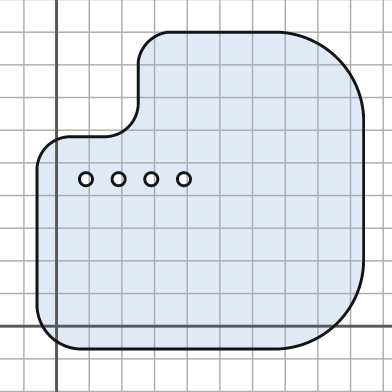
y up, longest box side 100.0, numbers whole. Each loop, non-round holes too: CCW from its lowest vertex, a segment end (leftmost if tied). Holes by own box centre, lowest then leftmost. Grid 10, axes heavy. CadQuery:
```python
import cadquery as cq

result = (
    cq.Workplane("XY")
    .moveTo(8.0, -7.0)
    .lineTo(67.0, -7.0)
    .threePointArc((86.0, 1.0), (94.0, 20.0))
    .lineTo(94.0, 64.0)
    .threePointArc((86.0, 82.0), (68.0, 90.0))
    .lineTo(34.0, 90.0)
    .threePointArc((28.0, 87.0), (25.0, 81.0))
    .lineTo(25.0, 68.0)
    .threePointArc((22.0, 61.0), (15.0, 58.0))
    .lineTo(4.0, 58.0)
    .threePointArc((-3.0, 55.0), (-6.0, 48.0))
    .lineTo(-6.0, 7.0)
    .threePointArc((-2.0, -3.0), (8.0, -7.0))
    .close()
    .moveTo(9.0, 45.0)
    .circle(2.0)
    .moveTo(19.0, 45.0)
    .circle(2.0)
    .moveTo(29.0, 45.0)
    .circle(2.0)
    .moveTo(39.0, 45.0)
    .circle(2.0)
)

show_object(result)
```